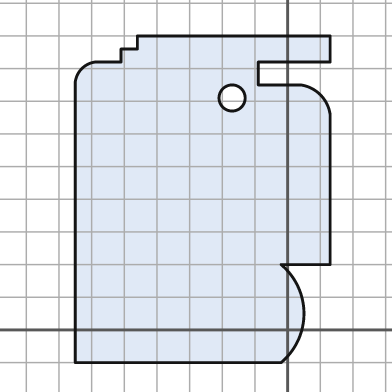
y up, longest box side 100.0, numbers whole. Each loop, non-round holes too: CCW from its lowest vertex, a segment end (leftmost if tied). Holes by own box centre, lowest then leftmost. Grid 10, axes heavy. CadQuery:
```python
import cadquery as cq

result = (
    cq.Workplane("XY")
    .moveTo(-65.0, -10.0)
    .lineTo(-2.0, -10.0)
    .threePointArc((5.0, 5.0), (-2.0, 20.0))
    .lineTo(13.0, 20.0)
    .lineTo(13.0, 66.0)
    .threePointArc((10.0, 72.0), (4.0, 75.0))
    .lineTo(-9.0, 75.0)
    .lineTo(-9.0, 82.0)
    .lineTo(13.0, 82.0)
    .lineTo(13.0, 90.0)
    .lineTo(-46.0, 90.0)
    .lineTo(-46.0, 86.0)
    .lineTo(-51.0, 86.0)
    .lineTo(-51.0, 82.0)
    .lineTo(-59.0, 82.0)
    .threePointArc((-63.0, 80.0), (-65.0, 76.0))
    .close()
    .moveTo(-17.0, 71.0)
    .circle(4.0)
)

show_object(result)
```